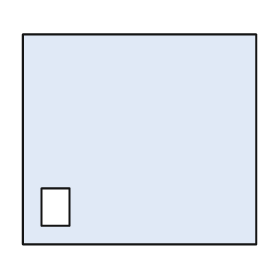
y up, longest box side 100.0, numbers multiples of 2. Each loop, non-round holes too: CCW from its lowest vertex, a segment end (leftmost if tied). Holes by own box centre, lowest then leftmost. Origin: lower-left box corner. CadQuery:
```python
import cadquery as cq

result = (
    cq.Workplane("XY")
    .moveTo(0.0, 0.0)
    .lineTo(100.0, 0.0)
    .lineTo(100.0, 90.0)
    .lineTo(0.0, 90.0)
    .close()
    .moveTo(8.0, 8.0)
    .lineTo(20.0, 8.0)
    .lineTo(20.0, 24.0)
    .lineTo(8.0, 24.0)
    .close()
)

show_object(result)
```